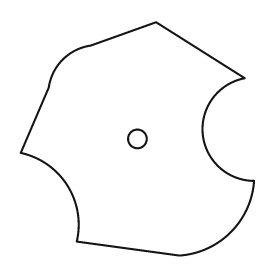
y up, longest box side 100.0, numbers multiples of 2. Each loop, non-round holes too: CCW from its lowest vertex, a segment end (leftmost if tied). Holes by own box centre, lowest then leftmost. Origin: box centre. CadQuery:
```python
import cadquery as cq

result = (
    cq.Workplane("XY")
    .moveTo(18.0, -50.0)
    .threePointArc((40.0, -40.0), (50.0, -18.0))
    .threePointArc((28.0, 2.0), (46.0, 26.0))
    .lineTo(8.0, 50.0)
    .lineTo(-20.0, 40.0)
    .threePointArc((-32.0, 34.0), (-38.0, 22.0))
    .lineTo(-50.0, -6.0)
    .threePointArc((-30.0, -20.0), (-26.0, -44.0))
    .close()
    .moveTo(0.0, 0.0)
    .circle(4.0)
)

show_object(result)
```